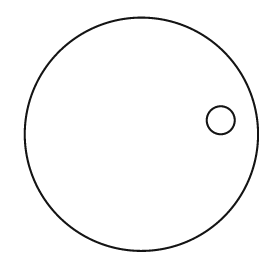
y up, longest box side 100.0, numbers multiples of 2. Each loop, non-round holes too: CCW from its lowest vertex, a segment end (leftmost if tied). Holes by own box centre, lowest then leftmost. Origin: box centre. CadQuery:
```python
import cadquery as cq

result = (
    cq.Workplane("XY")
    .moveTo(0.0, 0.0)
    .circle(50.0)
    .moveTo(34.0, 6.0)
    .circle(6.0)
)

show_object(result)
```